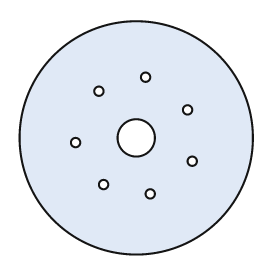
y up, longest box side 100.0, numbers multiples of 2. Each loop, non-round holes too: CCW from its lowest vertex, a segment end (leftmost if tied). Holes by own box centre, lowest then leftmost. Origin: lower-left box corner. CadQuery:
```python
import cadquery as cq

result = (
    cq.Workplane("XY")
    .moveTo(50.0, 50.0)
    .circle(50.0)
    .moveTo(56.0, 26.0)
    .circle(2.0)
    .moveTo(36.0, 30.0)
    .circle(2.0)
    .moveTo(74.0, 40.0)
    .circle(2.0)
    .moveTo(24.0, 48.0)
    .circle(2.0)
    .moveTo(50.0, 50.0)
    .circle(8.0)
    .moveTo(72.0, 62.0)
    .circle(2.0)
    .moveTo(34.0, 70.0)
    .circle(2.0)
    .moveTo(54.0, 76.0)
    .circle(2.0)
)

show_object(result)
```